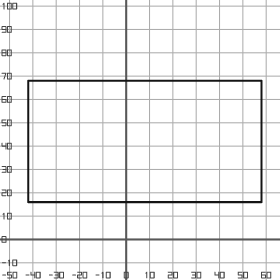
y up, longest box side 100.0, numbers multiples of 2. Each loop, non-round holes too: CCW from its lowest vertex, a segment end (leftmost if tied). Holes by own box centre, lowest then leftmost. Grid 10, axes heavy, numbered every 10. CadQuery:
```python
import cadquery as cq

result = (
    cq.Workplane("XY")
    .moveTo(-42.0, 16.0)
    .lineTo(58.0, 16.0)
    .lineTo(58.0, 68.0)
    .lineTo(-42.0, 68.0)
    .close()
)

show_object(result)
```